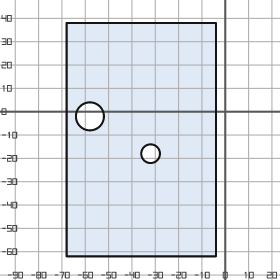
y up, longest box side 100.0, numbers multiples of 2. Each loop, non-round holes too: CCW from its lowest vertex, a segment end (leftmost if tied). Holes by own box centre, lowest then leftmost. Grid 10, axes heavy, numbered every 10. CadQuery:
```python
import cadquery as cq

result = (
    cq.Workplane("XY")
    .moveTo(-68.0, -62.0)
    .lineTo(-4.0, -62.0)
    .lineTo(-4.0, 38.0)
    .lineTo(-68.0, 38.0)
    .close()
    .moveTo(-32.0, -18.0)
    .circle(4.0)
    .moveTo(-58.0, -2.0)
    .circle(6.0)
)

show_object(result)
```